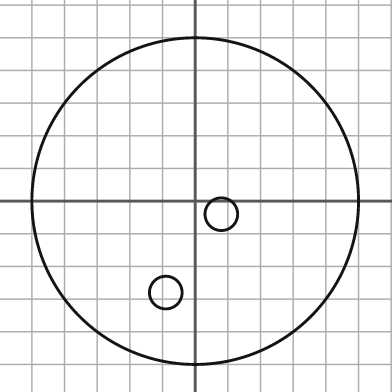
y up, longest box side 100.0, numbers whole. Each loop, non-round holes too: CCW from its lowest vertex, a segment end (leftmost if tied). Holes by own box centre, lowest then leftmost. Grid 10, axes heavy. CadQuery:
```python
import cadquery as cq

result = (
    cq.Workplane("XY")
    .moveTo(0.0, 0.0)
    .circle(50.0)
    .moveTo(-9.0, -28.0)
    .circle(5.0)
    .moveTo(8.0, -4.0)
    .circle(5.0)
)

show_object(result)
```